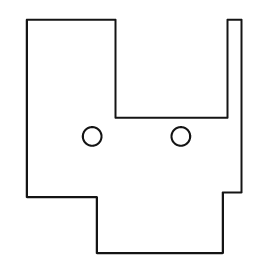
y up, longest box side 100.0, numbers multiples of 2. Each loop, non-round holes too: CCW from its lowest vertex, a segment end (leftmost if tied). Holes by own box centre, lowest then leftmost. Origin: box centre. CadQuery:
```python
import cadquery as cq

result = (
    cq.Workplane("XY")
    .moveTo(-16.0, -50.0)
    .lineTo(38.0, -50.0)
    .lineTo(38.0, -24.0)
    .lineTo(46.0, -24.0)
    .lineTo(46.0, 50.0)
    .lineTo(40.0, 50.0)
    .lineTo(40.0, 8.0)
    .lineTo(-8.0, 8.0)
    .lineTo(-8.0, 50.0)
    .lineTo(-46.0, 50.0)
    .lineTo(-46.0, -26.0)
    .lineTo(-16.0, -26.0)
    .close()
    .moveTo(-18.0, 0.0)
    .circle(4.0)
    .moveTo(20.0, 0.0)
    .circle(4.0)
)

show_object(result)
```